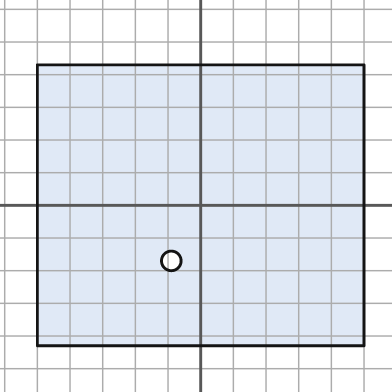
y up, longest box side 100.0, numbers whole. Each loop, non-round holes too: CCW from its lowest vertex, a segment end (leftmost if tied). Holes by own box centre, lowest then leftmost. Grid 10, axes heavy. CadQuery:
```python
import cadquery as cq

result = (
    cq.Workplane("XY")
    .moveTo(-50.0, -43.0)
    .lineTo(50.0, -43.0)
    .lineTo(50.0, 43.0)
    .lineTo(-50.0, 43.0)
    .close()
    .moveTo(-9.0, -17.0)
    .circle(3.0)
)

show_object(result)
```